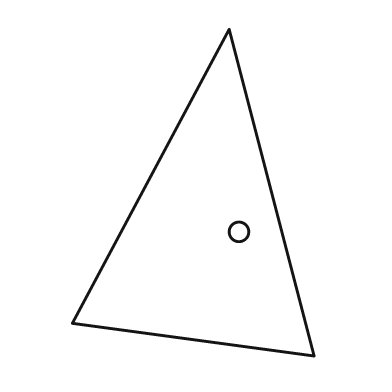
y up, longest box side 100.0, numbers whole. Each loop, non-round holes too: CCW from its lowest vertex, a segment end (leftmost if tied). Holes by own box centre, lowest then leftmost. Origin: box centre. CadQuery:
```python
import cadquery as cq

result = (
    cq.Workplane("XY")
    .moveTo(37.0, -50.0)
    .lineTo(11.0, 50.0)
    .lineTo(-37.0, -40.0)
    .close()
    .moveTo(14.0, -12.0)
    .circle(3.0)
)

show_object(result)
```